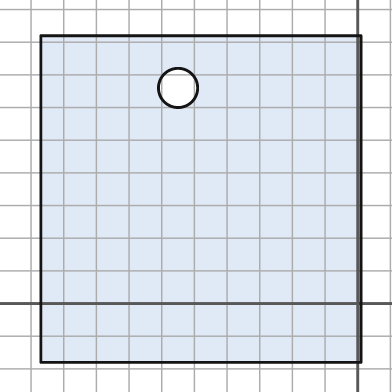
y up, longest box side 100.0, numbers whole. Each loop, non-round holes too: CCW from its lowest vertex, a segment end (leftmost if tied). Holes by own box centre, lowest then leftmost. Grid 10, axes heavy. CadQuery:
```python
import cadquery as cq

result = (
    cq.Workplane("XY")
    .moveTo(-97.0, -18.0)
    .lineTo(1.0, -18.0)
    .lineTo(1.0, 82.0)
    .lineTo(-97.0, 82.0)
    .close()
    .moveTo(-55.0, 66.0)
    .circle(6.0)
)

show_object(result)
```